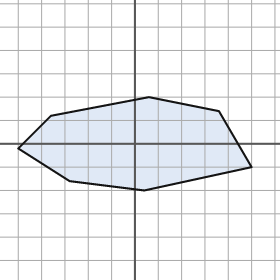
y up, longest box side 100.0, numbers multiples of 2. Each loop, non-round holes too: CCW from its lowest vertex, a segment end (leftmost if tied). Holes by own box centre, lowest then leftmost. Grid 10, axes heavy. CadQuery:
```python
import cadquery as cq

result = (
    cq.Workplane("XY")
    .moveTo(4.0, -20.0)
    .lineTo(50.0, -10.0)
    .lineTo(36.0, 14.0)
    .lineTo(6.0, 20.0)
    .lineTo(-36.0, 12.0)
    .lineTo(-50.0, -2.0)
    .lineTo(-28.0, -16.0)
    .close()
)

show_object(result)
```